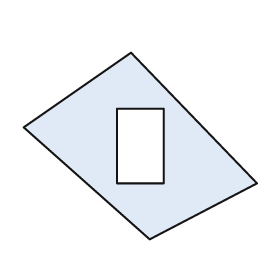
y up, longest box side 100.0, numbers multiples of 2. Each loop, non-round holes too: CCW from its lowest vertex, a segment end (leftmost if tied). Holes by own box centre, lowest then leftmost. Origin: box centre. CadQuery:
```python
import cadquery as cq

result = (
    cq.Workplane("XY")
    .moveTo(4.0, -40.0)
    .lineTo(50.0, -16.0)
    .lineTo(-4.0, 40.0)
    .lineTo(-50.0, 8.0)
    .close()
    .moveTo(-10.0, -16.0)
    .lineTo(10.0, -16.0)
    .lineTo(10.0, 16.0)
    .lineTo(-10.0, 16.0)
    .close()
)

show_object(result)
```